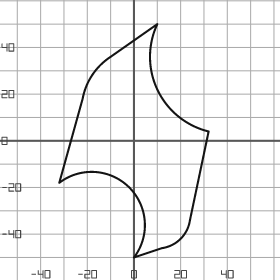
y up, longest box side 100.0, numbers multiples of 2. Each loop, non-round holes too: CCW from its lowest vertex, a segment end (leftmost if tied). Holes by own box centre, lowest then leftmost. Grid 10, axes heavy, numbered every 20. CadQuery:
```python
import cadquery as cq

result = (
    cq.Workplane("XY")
    .moveTo(0.0, -50.0)
    .lineTo(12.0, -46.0)
    .threePointArc((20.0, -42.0), (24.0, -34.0))
    .lineTo(32.0, 4.0)
    .threePointArc((10.0, 22.0), (10.0, 50.0))
    .lineTo(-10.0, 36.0)
    .threePointArc((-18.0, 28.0), (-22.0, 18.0))
    .lineTo(-32.0, -18.0)
    .threePointArc((-2.0, -20.0), (0.0, -50.0))
    .close()
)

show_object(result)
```